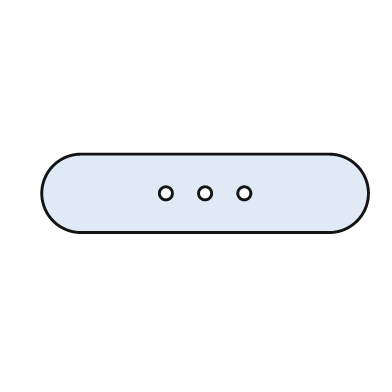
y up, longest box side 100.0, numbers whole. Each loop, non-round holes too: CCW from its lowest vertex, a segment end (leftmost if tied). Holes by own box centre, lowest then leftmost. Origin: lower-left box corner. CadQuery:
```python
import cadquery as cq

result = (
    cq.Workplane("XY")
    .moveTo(12.0, 0.0)
    .lineTo(88.0, 0.0)
    .threePointArc((100.0, 12.0), (88.0, 24.0))
    .lineTo(12.0, 24.0)
    .threePointArc((0.0, 12.0), (12.0, 0.0))
    .close()
    .moveTo(38.0, 12.0)
    .circle(2.0)
    .moveTo(50.0, 12.0)
    .circle(2.0)
    .moveTo(62.0, 12.0)
    .circle(2.0)
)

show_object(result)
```